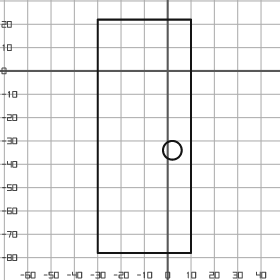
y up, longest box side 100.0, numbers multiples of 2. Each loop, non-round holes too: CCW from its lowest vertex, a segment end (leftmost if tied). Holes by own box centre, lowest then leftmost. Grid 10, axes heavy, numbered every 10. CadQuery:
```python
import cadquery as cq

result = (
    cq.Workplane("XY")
    .moveTo(-30.0, -78.0)
    .lineTo(10.0, -78.0)
    .lineTo(10.0, 22.0)
    .lineTo(-30.0, 22.0)
    .close()
    .moveTo(2.0, -34.0)
    .circle(4.0)
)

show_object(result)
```